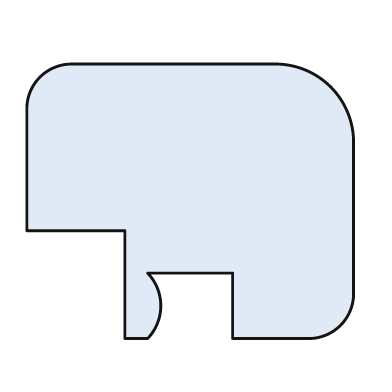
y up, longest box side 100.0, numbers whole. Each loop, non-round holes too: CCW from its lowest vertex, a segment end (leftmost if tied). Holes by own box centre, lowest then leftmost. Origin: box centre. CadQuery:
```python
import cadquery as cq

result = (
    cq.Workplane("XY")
    .moveTo(-20.0, -42.0)
    .lineTo(-13.0, -42.0)
    .threePointArc((-9.0, -32.0), (-13.0, -22.0))
    .lineTo(13.0, -22.0)
    .lineTo(13.0, -42.0)
    .lineTo(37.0, -42.0)
    .threePointArc((46.0, -38.0), (50.0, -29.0))
    .lineTo(50.0, 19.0)
    .threePointArc((43.0, 35.0), (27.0, 42.0))
    .lineTo(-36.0, 42.0)
    .threePointArc((-46.0, 38.0), (-50.0, 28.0))
    .lineTo(-50.0, -9.0)
    .lineTo(-20.0, -9.0)
    .close()
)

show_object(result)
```